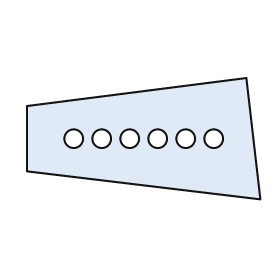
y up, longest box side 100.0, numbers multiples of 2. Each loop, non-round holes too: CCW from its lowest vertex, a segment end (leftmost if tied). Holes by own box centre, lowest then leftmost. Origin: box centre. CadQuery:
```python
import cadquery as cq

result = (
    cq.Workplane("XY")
    .moveTo(50.0, -26.0)
    .lineTo(44.0, 26.0)
    .lineTo(-50.0, 14.0)
    .lineTo(-50.0, -14.0)
    .close()
    .moveTo(-30.0, 0.0)
    .circle(4.0)
    .moveTo(-18.0, 0.0)
    .circle(4.0)
    .moveTo(-6.0, 0.0)
    .circle(4.0)
    .moveTo(6.0, 0.0)
    .circle(4.0)
    .moveTo(18.0, 0.0)
    .circle(4.0)
    .moveTo(30.0, 0.0)
    .circle(4.0)
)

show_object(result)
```